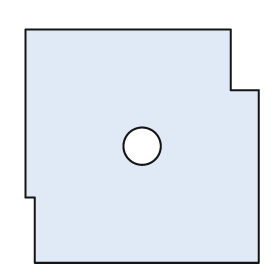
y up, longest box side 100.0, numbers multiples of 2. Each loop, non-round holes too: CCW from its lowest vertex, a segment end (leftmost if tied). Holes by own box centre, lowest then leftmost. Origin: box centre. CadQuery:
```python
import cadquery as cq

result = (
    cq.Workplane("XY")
    .moveTo(-46.0, -50.0)
    .lineTo(50.0, -50.0)
    .lineTo(50.0, 24.0)
    .lineTo(38.0, 24.0)
    .lineTo(38.0, 50.0)
    .lineTo(-50.0, 50.0)
    .lineTo(-50.0, -22.0)
    .lineTo(-46.0, -22.0)
    .close()
    .moveTo(0.0, 0.0)
    .circle(8.0)
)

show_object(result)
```